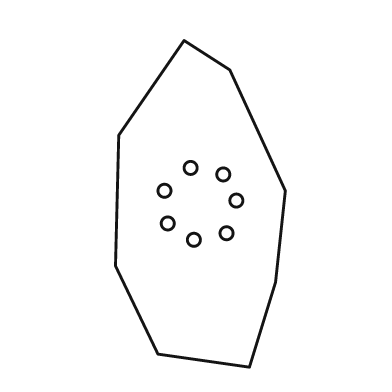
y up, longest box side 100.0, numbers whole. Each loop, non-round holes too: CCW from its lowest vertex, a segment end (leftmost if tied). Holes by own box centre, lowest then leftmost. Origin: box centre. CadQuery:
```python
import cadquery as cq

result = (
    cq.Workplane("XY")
    .moveTo(15.0, -50.0)
    .lineTo(23.0, -24.0)
    .lineTo(26.0, 4.0)
    .lineTo(9.0, 41.0)
    .lineTo(-5.0, 50.0)
    .lineTo(-25.0, 21.0)
    .lineTo(-26.0, -19.0)
    .lineTo(-13.0, -46.0)
    .close()
    .moveTo(-2.0, -11.0)
    .circle(2.0)
    .moveTo(8.0, -9.0)
    .circle(2.0)
    .moveTo(-10.0, -6.0)
    .circle(2.0)
    .moveTo(11.0, 1.0)
    .circle(2.0)
    .moveTo(-11.0, 4.0)
    .circle(2.0)
    .moveTo(7.0, 9.0)
    .circle(2.0)
    .moveTo(-3.0, 11.0)
    .circle(2.0)
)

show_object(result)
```